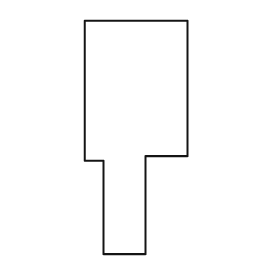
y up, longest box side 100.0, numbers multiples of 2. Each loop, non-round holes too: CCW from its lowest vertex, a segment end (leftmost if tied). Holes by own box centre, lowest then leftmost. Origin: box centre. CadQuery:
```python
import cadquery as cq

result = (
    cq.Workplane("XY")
    .moveTo(-14.0, -50.0)
    .lineTo(4.0, -50.0)
    .lineTo(4.0, -8.0)
    .lineTo(22.0, -8.0)
    .lineTo(22.0, 50.0)
    .lineTo(-22.0, 50.0)
    .lineTo(-22.0, -10.0)
    .lineTo(-14.0, -10.0)
    .close()
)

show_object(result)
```